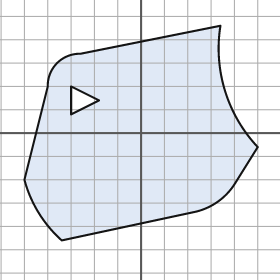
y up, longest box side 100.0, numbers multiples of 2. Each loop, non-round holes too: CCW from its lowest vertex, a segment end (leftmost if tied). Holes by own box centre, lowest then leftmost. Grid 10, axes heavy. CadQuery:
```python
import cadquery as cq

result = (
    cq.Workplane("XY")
    .moveTo(-34.0, -46.0)
    .lineTo(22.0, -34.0)
    .threePointArc((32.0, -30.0), (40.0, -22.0))
    .lineTo(50.0, -6.0)
    .threePointArc((36.0, 18.0), (34.0, 46.0))
    .lineTo(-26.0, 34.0)
    .threePointArc((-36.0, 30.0), (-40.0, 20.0))
    .lineTo(-50.0, -20.0)
    .threePointArc((-44.0, -34.0), (-34.0, -46.0))
    .close()
    .moveTo(-30.0, 8.0)
    .lineTo(-18.0, 14.0)
    .lineTo(-30.0, 20.0)
    .close()
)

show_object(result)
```